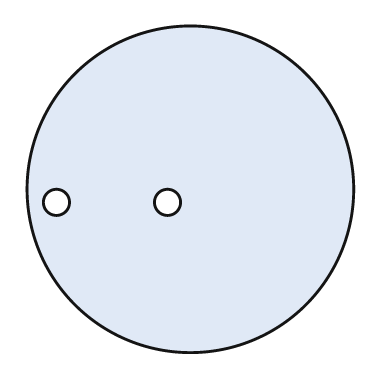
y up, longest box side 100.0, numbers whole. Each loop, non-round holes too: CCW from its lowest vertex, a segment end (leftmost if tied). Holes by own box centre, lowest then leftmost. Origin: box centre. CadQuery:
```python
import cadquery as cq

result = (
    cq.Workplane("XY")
    .moveTo(0.0, 0.0)
    .circle(50.0)
    .moveTo(-41.0, -4.0)
    .circle(4.0)
    .moveTo(-7.0, -4.0)
    .circle(4.0)
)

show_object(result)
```